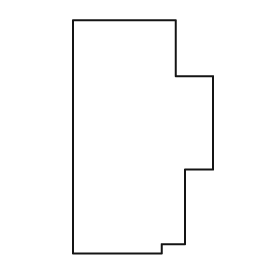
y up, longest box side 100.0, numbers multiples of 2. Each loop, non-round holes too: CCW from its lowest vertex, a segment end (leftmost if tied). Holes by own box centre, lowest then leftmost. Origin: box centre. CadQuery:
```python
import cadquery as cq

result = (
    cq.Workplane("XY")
    .moveTo(-30.0, -50.0)
    .lineTo(8.0, -50.0)
    .lineTo(8.0, -46.0)
    .lineTo(18.0, -46.0)
    .lineTo(18.0, -14.0)
    .lineTo(30.0, -14.0)
    .lineTo(30.0, 26.0)
    .lineTo(14.0, 26.0)
    .lineTo(14.0, 50.0)
    .lineTo(-30.0, 50.0)
    .close()
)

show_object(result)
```